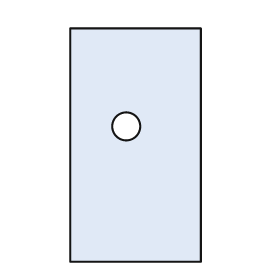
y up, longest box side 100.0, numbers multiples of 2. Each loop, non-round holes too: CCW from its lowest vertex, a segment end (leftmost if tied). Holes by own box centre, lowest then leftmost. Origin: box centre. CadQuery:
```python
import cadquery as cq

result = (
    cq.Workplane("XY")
    .moveTo(-28.0, -50.0)
    .lineTo(28.0, -50.0)
    .lineTo(28.0, 50.0)
    .lineTo(-28.0, 50.0)
    .close()
    .moveTo(-4.0, 8.0)
    .circle(6.0)
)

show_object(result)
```